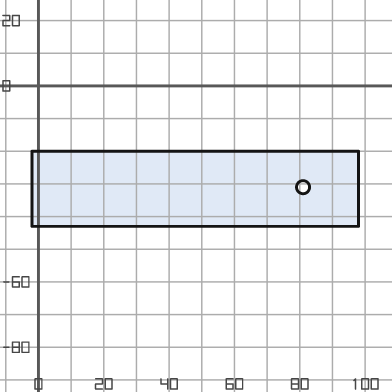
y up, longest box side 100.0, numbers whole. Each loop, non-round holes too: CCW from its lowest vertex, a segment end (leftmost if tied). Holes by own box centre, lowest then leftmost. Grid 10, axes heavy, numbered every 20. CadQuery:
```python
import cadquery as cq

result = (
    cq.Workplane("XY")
    .moveTo(-2.0, -43.0)
    .lineTo(98.0, -43.0)
    .lineTo(98.0, -20.0)
    .lineTo(-2.0, -20.0)
    .close()
    .moveTo(81.0, -31.0)
    .circle(2.0)
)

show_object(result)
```